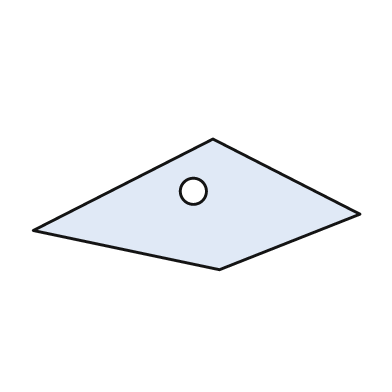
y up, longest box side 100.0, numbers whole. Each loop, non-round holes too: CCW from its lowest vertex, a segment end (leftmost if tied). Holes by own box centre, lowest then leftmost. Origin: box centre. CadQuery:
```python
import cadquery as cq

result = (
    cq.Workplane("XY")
    .moveTo(7.0, -20.0)
    .lineTo(50.0, -3.0)
    .lineTo(5.0, 20.0)
    .lineTo(-50.0, -8.0)
    .close()
    .moveTo(-1.0, 4.0)
    .circle(4.0)
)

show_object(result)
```